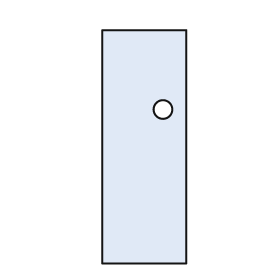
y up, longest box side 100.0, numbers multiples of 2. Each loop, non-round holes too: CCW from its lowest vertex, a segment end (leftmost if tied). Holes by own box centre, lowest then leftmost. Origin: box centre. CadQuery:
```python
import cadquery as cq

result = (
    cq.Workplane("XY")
    .moveTo(-18.0, -50.0)
    .lineTo(18.0, -50.0)
    .lineTo(18.0, 50.0)
    .lineTo(-18.0, 50.0)
    .close()
    .moveTo(8.0, 16.0)
    .circle(4.0)
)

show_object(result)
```